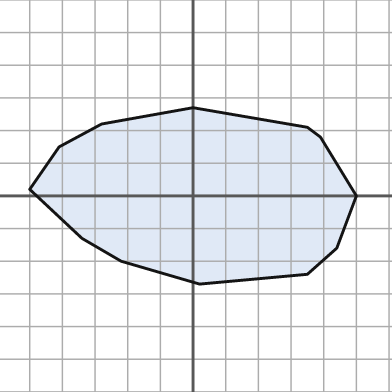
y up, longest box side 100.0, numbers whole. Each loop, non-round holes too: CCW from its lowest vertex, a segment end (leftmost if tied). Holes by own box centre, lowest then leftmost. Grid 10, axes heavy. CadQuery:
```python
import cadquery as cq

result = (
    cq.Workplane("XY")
    .moveTo(2.0, -27.0)
    .lineTo(35.0, -24.0)
    .lineTo(44.0, -16.0)
    .lineTo(50.0, 0.0)
    .lineTo(39.0, 18.0)
    .lineTo(35.0, 21.0)
    .lineTo(0.0, 27.0)
    .lineTo(-28.0, 22.0)
    .lineTo(-41.0, 15.0)
    .lineTo(-50.0, 2.0)
    .lineTo(-34.0, -13.0)
    .lineTo(-22.0, -20.0)
    .close()
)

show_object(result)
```